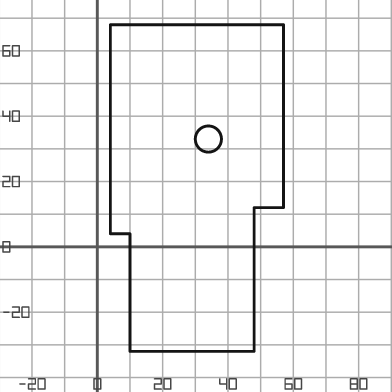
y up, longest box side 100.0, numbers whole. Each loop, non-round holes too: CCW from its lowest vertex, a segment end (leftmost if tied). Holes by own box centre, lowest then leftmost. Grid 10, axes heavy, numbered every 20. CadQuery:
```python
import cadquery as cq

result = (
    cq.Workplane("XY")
    .moveTo(10.0, -32.0)
    .lineTo(48.0, -32.0)
    .lineTo(48.0, 12.0)
    .lineTo(57.0, 12.0)
    .lineTo(57.0, 68.0)
    .lineTo(4.0, 68.0)
    .lineTo(4.0, 4.0)
    .lineTo(10.0, 4.0)
    .close()
    .moveTo(34.0, 33.0)
    .circle(4.0)
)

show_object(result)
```